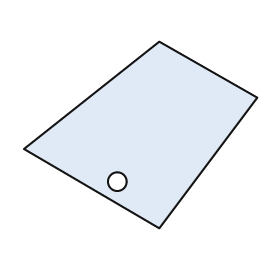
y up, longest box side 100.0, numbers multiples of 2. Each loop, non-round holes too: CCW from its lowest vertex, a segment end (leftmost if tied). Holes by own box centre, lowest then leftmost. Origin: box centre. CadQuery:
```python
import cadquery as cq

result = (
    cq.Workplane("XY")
    .moveTo(8.0, -40.0)
    .lineTo(50.0, 16.0)
    .lineTo(8.0, 40.0)
    .lineTo(-50.0, -6.0)
    .close()
    .moveTo(-10.0, -20.0)
    .circle(4.0)
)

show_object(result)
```